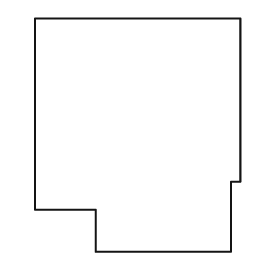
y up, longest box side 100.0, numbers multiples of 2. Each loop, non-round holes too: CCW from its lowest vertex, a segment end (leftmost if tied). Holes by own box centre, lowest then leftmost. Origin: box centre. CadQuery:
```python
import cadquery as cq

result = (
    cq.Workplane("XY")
    .moveTo(-18.0, -50.0)
    .lineTo(40.0, -50.0)
    .lineTo(40.0, -20.0)
    .lineTo(44.0, -20.0)
    .lineTo(44.0, 50.0)
    .lineTo(-44.0, 50.0)
    .lineTo(-44.0, -32.0)
    .lineTo(-18.0, -32.0)
    .close()
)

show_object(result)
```